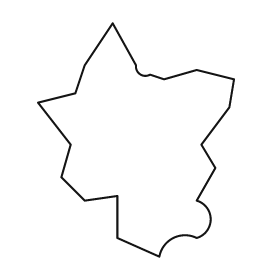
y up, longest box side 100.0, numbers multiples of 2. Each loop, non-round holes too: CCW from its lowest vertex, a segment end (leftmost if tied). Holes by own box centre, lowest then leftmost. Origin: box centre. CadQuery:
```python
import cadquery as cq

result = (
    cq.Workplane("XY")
    .moveTo(10.0, -50.0)
    .threePointArc((16.0, -42.0), (26.0, -42.0))
    .threePointArc((32.0, -34.0), (26.0, -26.0))
    .lineTo(34.0, -12.0)
    .lineTo(28.0, -2.0)
    .lineTo(40.0, 14.0)
    .lineTo(42.0, 26.0)
    .lineTo(26.0, 30.0)
    .lineTo(12.0, 26.0)
    .lineTo(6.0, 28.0)
    .threePointArc((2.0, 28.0), (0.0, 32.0))
    .lineTo(-10.0, 50.0)
    .lineTo(-22.0, 32.0)
    .lineTo(-26.0, 20.0)
    .lineTo(-42.0, 16.0)
    .lineTo(-28.0, -2.0)
    .lineTo(-32.0, -16.0)
    .lineTo(-22.0, -26.0)
    .lineTo(-8.0, -24.0)
    .lineTo(-8.0, -42.0)
    .close()
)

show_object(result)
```